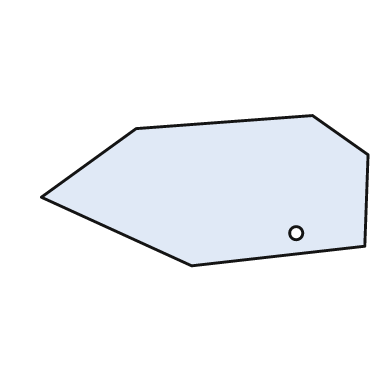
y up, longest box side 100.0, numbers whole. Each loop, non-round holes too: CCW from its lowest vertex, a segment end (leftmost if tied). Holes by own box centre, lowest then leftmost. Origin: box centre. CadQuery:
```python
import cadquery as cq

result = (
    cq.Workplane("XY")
    .moveTo(-4.0, -23.0)
    .lineTo(49.0, -17.0)
    .lineTo(50.0, 11.0)
    .lineTo(33.0, 23.0)
    .lineTo(-21.0, 19.0)
    .lineTo(-50.0, -2.0)
    .close()
    .moveTo(28.0, -13.0)
    .circle(2.0)
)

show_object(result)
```